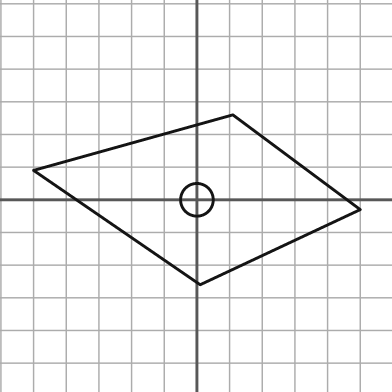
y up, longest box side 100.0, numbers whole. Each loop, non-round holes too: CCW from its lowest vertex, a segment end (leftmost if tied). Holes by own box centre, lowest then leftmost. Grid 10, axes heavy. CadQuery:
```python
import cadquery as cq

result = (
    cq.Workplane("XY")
    .moveTo(1.0, -26.0)
    .lineTo(50.0, -3.0)
    .lineTo(11.0, 26.0)
    .lineTo(-50.0, 9.0)
    .close()
    .moveTo(0.0, 0.0)
    .circle(5.0)
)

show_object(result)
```